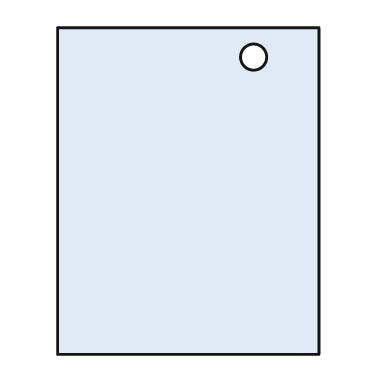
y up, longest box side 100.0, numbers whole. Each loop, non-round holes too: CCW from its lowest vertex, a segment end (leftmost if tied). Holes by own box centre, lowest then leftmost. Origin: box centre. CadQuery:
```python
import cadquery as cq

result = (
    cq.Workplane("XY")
    .moveTo(-40.0, -50.0)
    .lineTo(40.0, -50.0)
    .lineTo(40.0, 50.0)
    .lineTo(-40.0, 50.0)
    .close()
    .moveTo(20.0, 41.0)
    .circle(4.0)
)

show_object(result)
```